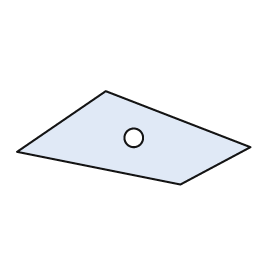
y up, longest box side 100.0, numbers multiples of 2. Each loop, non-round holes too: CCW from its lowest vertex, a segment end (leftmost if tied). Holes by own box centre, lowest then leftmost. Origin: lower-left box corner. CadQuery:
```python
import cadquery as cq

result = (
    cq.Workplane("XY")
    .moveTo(70.0, 0.0)
    .lineTo(100.0, 16.0)
    .lineTo(38.0, 40.0)
    .lineTo(0.0, 14.0)
    .close()
    .moveTo(50.0, 20.0)
    .circle(4.0)
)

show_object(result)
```